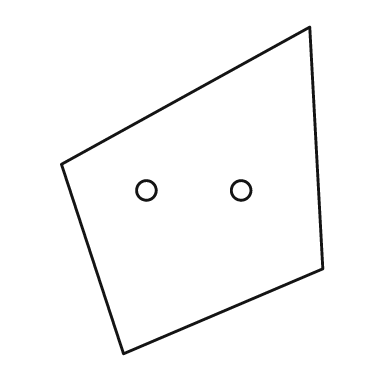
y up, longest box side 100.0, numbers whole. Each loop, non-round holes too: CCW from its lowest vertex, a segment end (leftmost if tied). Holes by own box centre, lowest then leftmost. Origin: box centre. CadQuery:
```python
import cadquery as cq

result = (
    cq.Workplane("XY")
    .moveTo(-21.0, -50.0)
    .lineTo(40.0, -24.0)
    .lineTo(36.0, 50.0)
    .lineTo(-40.0, 8.0)
    .close()
    .moveTo(-14.0, 0.0)
    .circle(3.0)
    .moveTo(15.0, 0.0)
    .circle(3.0)
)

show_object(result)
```